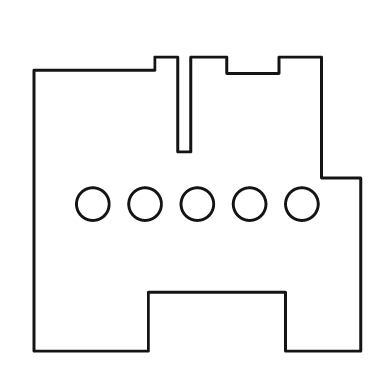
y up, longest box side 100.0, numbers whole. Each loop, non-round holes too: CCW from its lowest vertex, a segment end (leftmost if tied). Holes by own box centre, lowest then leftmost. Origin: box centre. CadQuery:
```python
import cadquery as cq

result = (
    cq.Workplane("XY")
    .moveTo(-50.0, -45.0)
    .lineTo(-15.0, -45.0)
    .lineTo(-15.0, -27.0)
    .lineTo(27.0, -27.0)
    .lineTo(27.0, -45.0)
    .lineTo(50.0, -45.0)
    .lineTo(50.0, 8.0)
    .lineTo(38.0, 8.0)
    .lineTo(38.0, 45.0)
    .lineTo(25.0, 45.0)
    .lineTo(25.0, 40.0)
    .lineTo(9.0, 40.0)
    .lineTo(9.0, 45.0)
    .lineTo(-2.0, 45.0)
    .lineTo(-2.0, 16.0)
    .lineTo(-6.0, 16.0)
    .lineTo(-6.0, 45.0)
    .lineTo(-13.0, 45.0)
    .lineTo(-13.0, 41.0)
    .lineTo(-50.0, 41.0)
    .close()
    .moveTo(-32.0, 0.0)
    .circle(5.0)
    .moveTo(-16.0, 0.0)
    .circle(5.0)
    .moveTo(0.0, 0.0)
    .circle(5.0)
    .moveTo(16.0, 0.0)
    .circle(5.0)
    .moveTo(32.0, 0.0)
    .circle(5.0)
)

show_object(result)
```